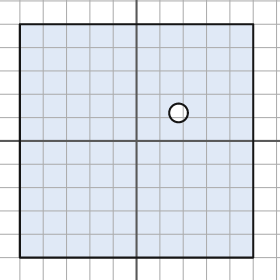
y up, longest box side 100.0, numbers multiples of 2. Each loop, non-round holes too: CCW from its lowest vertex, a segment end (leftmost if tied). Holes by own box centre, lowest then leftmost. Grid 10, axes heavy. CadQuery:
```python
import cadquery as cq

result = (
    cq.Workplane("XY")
    .moveTo(-50.0, -50.0)
    .lineTo(50.0, -50.0)
    .lineTo(50.0, 50.0)
    .lineTo(-50.0, 50.0)
    .close()
    .moveTo(18.0, 12.0)
    .circle(4.0)
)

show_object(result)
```